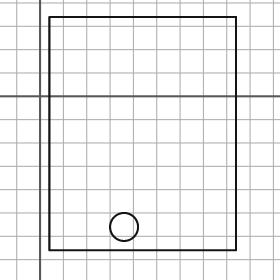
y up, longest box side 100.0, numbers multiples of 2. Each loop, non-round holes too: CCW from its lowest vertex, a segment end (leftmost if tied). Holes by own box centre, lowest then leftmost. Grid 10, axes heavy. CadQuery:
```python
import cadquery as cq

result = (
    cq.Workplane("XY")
    .moveTo(4.0, -66.0)
    .lineTo(84.0, -66.0)
    .lineTo(84.0, 34.0)
    .lineTo(4.0, 34.0)
    .close()
    .moveTo(36.0, -56.0)
    .circle(6.0)
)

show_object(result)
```